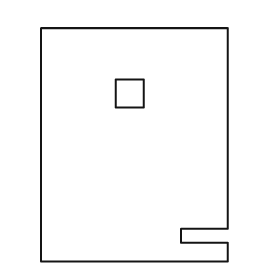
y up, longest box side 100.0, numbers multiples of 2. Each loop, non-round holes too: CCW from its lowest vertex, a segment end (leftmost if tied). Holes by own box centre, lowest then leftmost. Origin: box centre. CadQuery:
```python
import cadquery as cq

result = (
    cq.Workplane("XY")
    .moveTo(-40.0, -50.0)
    .lineTo(40.0, -50.0)
    .lineTo(40.0, -42.0)
    .lineTo(20.0, -42.0)
    .lineTo(20.0, -36.0)
    .lineTo(40.0, -36.0)
    .lineTo(40.0, 50.0)
    .lineTo(-40.0, 50.0)
    .close()
    .moveTo(-8.0, 16.0)
    .lineTo(4.0, 16.0)
    .lineTo(4.0, 28.0)
    .lineTo(-8.0, 28.0)
    .close()
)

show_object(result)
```